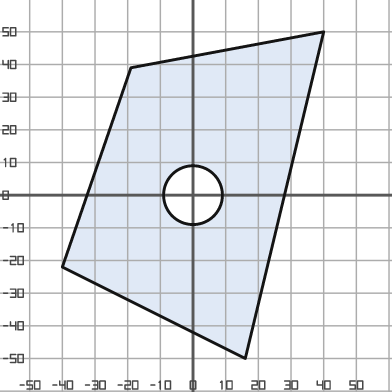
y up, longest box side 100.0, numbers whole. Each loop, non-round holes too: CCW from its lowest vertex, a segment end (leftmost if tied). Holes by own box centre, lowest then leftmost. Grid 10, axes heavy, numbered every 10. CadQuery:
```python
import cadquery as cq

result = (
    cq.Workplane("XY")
    .moveTo(16.0, -50.0)
    .lineTo(40.0, 50.0)
    .lineTo(-19.0, 39.0)
    .lineTo(-40.0, -22.0)
    .close()
    .moveTo(0.0, 0.0)
    .circle(9.0)
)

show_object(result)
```